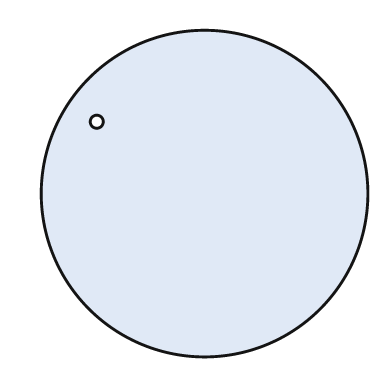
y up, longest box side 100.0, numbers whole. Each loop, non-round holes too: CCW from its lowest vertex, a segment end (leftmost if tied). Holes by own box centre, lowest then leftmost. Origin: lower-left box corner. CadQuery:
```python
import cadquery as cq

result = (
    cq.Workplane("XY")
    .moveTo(50.0, 50.0)
    .circle(50.0)
    .moveTo(17.0, 72.0)
    .circle(2.0)
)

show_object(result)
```